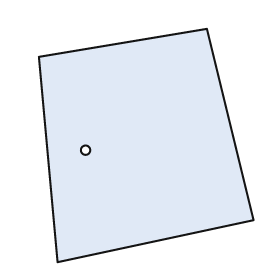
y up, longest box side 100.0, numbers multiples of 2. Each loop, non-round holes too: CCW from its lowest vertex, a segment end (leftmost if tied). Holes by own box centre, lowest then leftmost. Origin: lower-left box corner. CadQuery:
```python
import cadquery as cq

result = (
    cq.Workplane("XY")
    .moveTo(8.0, 0.0)
    .lineTo(92.0, 18.0)
    .lineTo(72.0, 100.0)
    .lineTo(0.0, 88.0)
    .close()
    .moveTo(20.0, 48.0)
    .circle(2.0)
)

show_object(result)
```